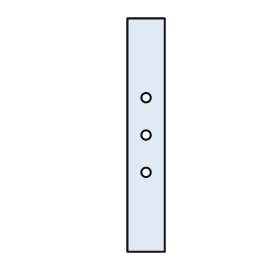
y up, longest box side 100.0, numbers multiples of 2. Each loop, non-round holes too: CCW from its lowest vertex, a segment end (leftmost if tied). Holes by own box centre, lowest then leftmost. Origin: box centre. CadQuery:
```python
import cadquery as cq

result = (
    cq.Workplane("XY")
    .moveTo(-8.0, -50.0)
    .lineTo(8.0, -50.0)
    .lineTo(8.0, 50.0)
    .lineTo(-8.0, 50.0)
    .close()
    .moveTo(0.0, -16.0)
    .circle(2.0)
    .moveTo(0.0, 0.0)
    .circle(2.0)
    .moveTo(0.0, 16.0)
    .circle(2.0)
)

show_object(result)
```